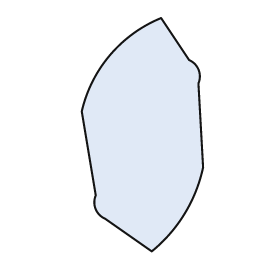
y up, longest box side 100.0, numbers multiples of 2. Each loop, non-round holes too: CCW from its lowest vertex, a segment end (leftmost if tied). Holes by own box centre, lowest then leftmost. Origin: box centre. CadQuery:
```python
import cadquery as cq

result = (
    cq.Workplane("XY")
    .moveTo(4.0, -50.0)
    .threePointArc((18.0, -34.0), (26.0, -14.0))
    .lineTo(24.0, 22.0)
    .threePointArc((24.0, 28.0), (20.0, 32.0))
    .lineTo(8.0, 50.0)
    .threePointArc((-14.0, 34.0), (-26.0, 10.0))
    .lineTo(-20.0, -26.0)
    .threePointArc((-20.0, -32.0), (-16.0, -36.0))
    .close()
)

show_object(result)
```